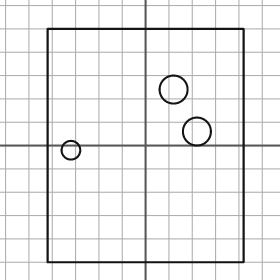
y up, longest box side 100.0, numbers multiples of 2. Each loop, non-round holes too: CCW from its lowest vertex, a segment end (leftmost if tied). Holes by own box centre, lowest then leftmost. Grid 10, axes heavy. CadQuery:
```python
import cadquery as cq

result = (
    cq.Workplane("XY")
    .moveTo(-42.0, -50.0)
    .lineTo(42.0, -50.0)
    .lineTo(42.0, 50.0)
    .lineTo(-42.0, 50.0)
    .close()
    .moveTo(-32.0, -2.0)
    .circle(4.0)
    .moveTo(22.0, 6.0)
    .circle(6.0)
    .moveTo(12.0, 24.0)
    .circle(6.0)
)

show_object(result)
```